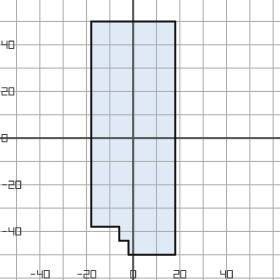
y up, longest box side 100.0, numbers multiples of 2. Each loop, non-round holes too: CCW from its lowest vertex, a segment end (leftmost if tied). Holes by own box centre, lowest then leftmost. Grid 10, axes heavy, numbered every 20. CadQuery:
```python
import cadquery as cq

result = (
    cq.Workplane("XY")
    .moveTo(-2.0, -50.0)
    .lineTo(18.0, -50.0)
    .lineTo(18.0, 50.0)
    .lineTo(-18.0, 50.0)
    .lineTo(-18.0, -38.0)
    .lineTo(-6.0, -38.0)
    .lineTo(-6.0, -44.0)
    .lineTo(-2.0, -44.0)
    .close()
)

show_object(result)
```